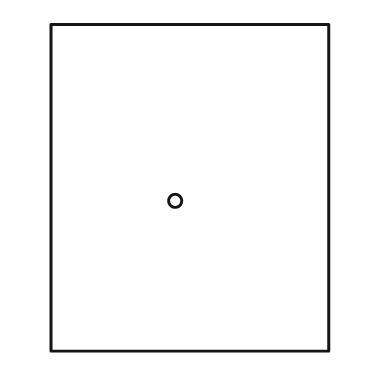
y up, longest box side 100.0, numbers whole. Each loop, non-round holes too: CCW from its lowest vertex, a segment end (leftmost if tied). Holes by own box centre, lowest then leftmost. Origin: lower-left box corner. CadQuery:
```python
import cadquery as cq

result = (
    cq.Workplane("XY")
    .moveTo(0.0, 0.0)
    .lineTo(85.0, 0.0)
    .lineTo(85.0, 100.0)
    .lineTo(0.0, 100.0)
    .close()
    .moveTo(38.0, 46.0)
    .circle(2.0)
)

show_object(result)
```